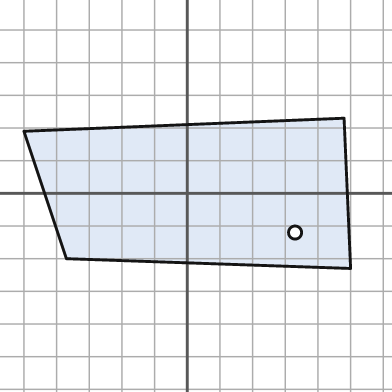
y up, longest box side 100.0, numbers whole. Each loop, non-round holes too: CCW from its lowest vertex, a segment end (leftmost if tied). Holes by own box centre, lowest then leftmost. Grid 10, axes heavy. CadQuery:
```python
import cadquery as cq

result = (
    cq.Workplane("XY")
    .moveTo(50.0, -23.0)
    .lineTo(48.0, 23.0)
    .lineTo(-50.0, 19.0)
    .lineTo(-37.0, -20.0)
    .close()
    .moveTo(33.0, -12.0)
    .circle(2.0)
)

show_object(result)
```